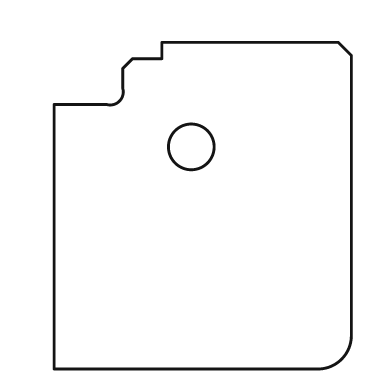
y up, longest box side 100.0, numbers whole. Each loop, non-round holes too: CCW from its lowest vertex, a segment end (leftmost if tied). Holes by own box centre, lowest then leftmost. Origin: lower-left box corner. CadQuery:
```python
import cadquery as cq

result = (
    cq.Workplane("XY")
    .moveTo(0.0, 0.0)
    .lineTo(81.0, 0.0)
    .threePointArc((88.0, 3.0), (91.0, 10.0))
    .lineTo(91.0, 96.0)
    .lineTo(87.0, 100.0)
    .lineTo(33.0, 100.0)
    .lineTo(33.0, 95.0)
    .lineTo(24.0, 95.0)
    .lineTo(21.0, 92.0)
    .lineTo(21.0, 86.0)
    .threePointArc((20.0, 82.0), (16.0, 81.0))
    .lineTo(0.0, 81.0)
    .close()
    .moveTo(42.0, 68.0)
    .circle(7.0)
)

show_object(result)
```